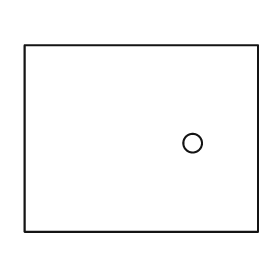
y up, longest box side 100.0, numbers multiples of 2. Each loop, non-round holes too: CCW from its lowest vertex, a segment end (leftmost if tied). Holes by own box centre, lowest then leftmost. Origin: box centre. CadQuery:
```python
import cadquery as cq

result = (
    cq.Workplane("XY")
    .moveTo(-50.0, -40.0)
    .lineTo(50.0, -40.0)
    .lineTo(50.0, 40.0)
    .lineTo(-50.0, 40.0)
    .close()
    .moveTo(22.0, -2.0)
    .circle(4.0)
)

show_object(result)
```